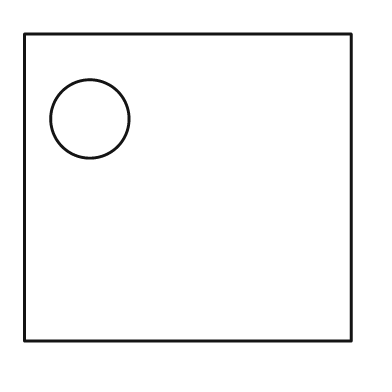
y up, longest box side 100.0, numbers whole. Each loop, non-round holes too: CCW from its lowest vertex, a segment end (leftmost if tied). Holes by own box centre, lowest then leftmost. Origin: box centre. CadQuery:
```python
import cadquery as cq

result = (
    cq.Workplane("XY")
    .moveTo(-50.0, -47.0)
    .lineTo(50.0, -47.0)
    .lineTo(50.0, 47.0)
    .lineTo(-50.0, 47.0)
    .close()
    .moveTo(-30.0, 21.0)
    .circle(12.0)
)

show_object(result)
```